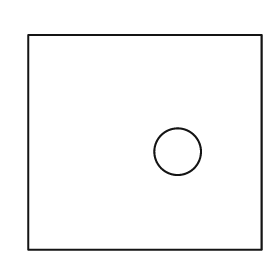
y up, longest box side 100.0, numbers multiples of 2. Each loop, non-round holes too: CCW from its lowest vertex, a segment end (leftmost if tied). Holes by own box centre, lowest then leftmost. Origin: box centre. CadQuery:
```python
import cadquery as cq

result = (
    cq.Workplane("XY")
    .moveTo(-50.0, -46.0)
    .lineTo(50.0, -46.0)
    .lineTo(50.0, 46.0)
    .lineTo(-50.0, 46.0)
    .close()
    .moveTo(14.0, -4.0)
    .circle(10.0)
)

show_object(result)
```